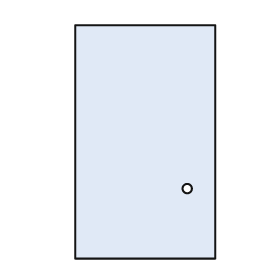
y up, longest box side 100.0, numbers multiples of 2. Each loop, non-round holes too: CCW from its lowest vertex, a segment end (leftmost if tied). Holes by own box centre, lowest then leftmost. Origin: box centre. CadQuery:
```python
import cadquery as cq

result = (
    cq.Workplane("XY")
    .moveTo(-30.0, -50.0)
    .lineTo(30.0, -50.0)
    .lineTo(30.0, 50.0)
    .lineTo(-30.0, 50.0)
    .close()
    .moveTo(18.0, -20.0)
    .circle(2.0)
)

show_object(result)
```